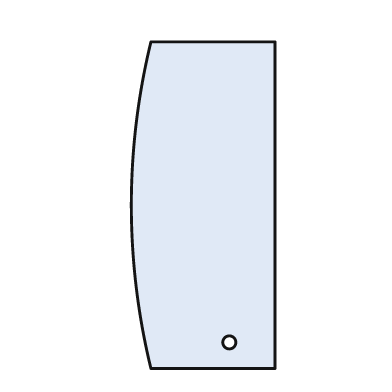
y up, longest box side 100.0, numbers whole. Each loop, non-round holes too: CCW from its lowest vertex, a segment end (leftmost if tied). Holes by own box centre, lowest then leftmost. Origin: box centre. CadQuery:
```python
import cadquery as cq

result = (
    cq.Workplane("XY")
    .moveTo(-16.0, -50.0)
    .lineTo(22.0, -50.0)
    .lineTo(22.0, 50.0)
    .lineTo(-16.0, 50.0)
    .threePointArc((-22.0, 0.0), (-16.0, -50.0))
    .close()
    .moveTo(8.0, -42.0)
    .circle(2.0)
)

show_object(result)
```